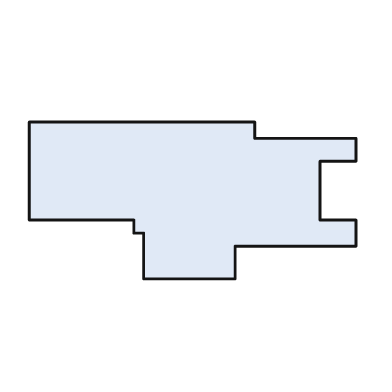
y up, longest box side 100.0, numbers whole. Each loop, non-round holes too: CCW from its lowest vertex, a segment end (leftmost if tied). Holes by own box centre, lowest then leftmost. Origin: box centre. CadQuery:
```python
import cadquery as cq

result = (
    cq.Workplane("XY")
    .moveTo(-15.0, -24.0)
    .lineTo(13.0, -24.0)
    .lineTo(13.0, -14.0)
    .lineTo(50.0, -14.0)
    .lineTo(50.0, -6.0)
    .lineTo(39.0, -6.0)
    .lineTo(39.0, 12.0)
    .lineTo(50.0, 12.0)
    .lineTo(50.0, 19.0)
    .lineTo(19.0, 19.0)
    .lineTo(19.0, 24.0)
    .lineTo(-50.0, 24.0)
    .lineTo(-50.0, -6.0)
    .lineTo(-18.0, -6.0)
    .lineTo(-18.0, -10.0)
    .lineTo(-15.0, -10.0)
    .close()
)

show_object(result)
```